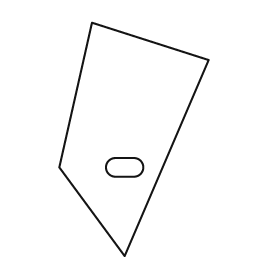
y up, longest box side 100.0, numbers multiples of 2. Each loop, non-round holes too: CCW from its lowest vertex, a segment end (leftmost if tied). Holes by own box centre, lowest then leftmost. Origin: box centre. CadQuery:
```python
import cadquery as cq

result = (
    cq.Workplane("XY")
    .moveTo(-4.0, -50.0)
    .lineTo(32.0, 34.0)
    .lineTo(-18.0, 50.0)
    .lineTo(-32.0, -12.0)
    .close()
    .moveTo(-8.0, -16.0)
    .lineTo(0.0, -16.0)
    .threePointArc((4.0, -12.0), (0.0, -8.0))
    .lineTo(-8.0, -8.0)
    .threePointArc((-12.0, -12.0), (-8.0, -16.0))
    .close()
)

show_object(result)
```